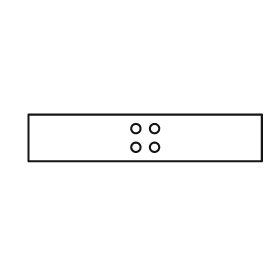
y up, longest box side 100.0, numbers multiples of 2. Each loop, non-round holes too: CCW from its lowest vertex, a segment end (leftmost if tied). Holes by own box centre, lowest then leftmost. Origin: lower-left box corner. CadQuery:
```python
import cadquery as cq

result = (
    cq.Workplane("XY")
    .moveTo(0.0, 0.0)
    .lineTo(100.0, 0.0)
    .lineTo(100.0, 20.0)
    .lineTo(0.0, 20.0)
    .close()
    .moveTo(46.0, 6.0)
    .circle(2.0)
    .moveTo(54.0, 6.0)
    .circle(2.0)
    .moveTo(46.0, 14.0)
    .circle(2.0)
    .moveTo(54.0, 14.0)
    .circle(2.0)
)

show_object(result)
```